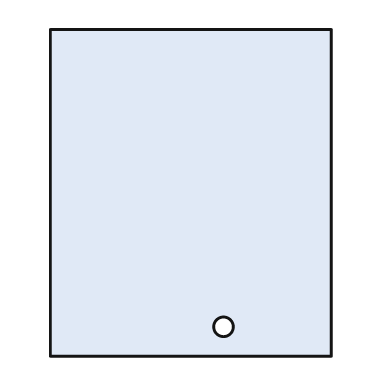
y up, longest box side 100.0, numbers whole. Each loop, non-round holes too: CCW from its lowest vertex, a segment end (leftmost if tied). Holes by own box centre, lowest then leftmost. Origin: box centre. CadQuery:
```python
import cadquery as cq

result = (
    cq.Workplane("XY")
    .moveTo(-43.0, -50.0)
    .lineTo(43.0, -50.0)
    .lineTo(43.0, 50.0)
    .lineTo(-43.0, 50.0)
    .close()
    .moveTo(10.0, -41.0)
    .circle(3.0)
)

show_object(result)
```